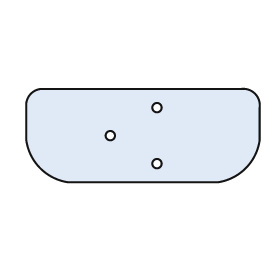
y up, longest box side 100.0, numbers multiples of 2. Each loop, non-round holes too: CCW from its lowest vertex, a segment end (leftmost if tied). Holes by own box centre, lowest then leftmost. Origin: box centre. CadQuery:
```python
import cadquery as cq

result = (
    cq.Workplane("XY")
    .moveTo(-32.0, -20.0)
    .lineTo(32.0, -20.0)
    .threePointArc((44.0, -14.0), (50.0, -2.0))
    .lineTo(50.0, 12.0)
    .threePointArc((48.0, 18.0), (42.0, 20.0))
    .lineTo(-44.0, 20.0)
    .threePointArc((-48.0, 18.0), (-50.0, 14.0))
    .lineTo(-50.0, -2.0)
    .threePointArc((-44.0, -14.0), (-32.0, -20.0))
    .close()
    .moveTo(6.0, -12.0)
    .circle(2.0)
    .moveTo(-14.0, 0.0)
    .circle(2.0)
    .moveTo(6.0, 12.0)
    .circle(2.0)
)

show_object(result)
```